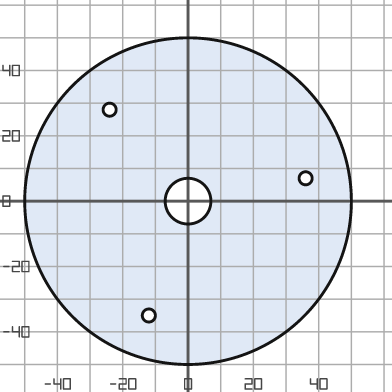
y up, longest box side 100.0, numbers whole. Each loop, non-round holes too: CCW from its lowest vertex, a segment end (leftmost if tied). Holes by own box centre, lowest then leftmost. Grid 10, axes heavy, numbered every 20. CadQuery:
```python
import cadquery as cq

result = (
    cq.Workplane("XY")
    .moveTo(0.0, 0.0)
    .circle(50.0)
    .moveTo(-12.0, -35.0)
    .circle(2.0)
    .moveTo(0.0, 0.0)
    .circle(7.0)
    .moveTo(36.0, 7.0)
    .circle(2.0)
    .moveTo(-24.0, 28.0)
    .circle(2.0)
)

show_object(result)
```